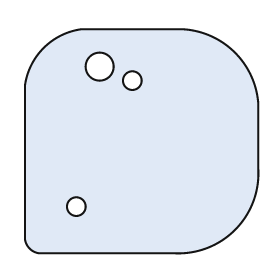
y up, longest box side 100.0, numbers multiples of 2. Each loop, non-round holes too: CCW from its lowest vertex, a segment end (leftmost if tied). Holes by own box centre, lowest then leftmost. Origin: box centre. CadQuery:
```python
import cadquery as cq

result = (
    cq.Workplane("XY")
    .moveTo(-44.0, -48.0)
    .lineTo(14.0, -48.0)
    .threePointArc((40.0, -38.0), (50.0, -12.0))
    .lineTo(50.0, 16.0)
    .threePointArc((40.0, 38.0), (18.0, 48.0))
    .lineTo(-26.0, 48.0)
    .threePointArc((-42.0, 40.0), (-50.0, 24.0))
    .lineTo(-50.0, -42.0)
    .threePointArc((-48.0, -46.0), (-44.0, -48.0))
    .close()
    .moveTo(-28.0, -28.0)
    .circle(4.0)
    .moveTo(-4.0, 26.0)
    .circle(4.0)
    .moveTo(-18.0, 32.0)
    .circle(6.0)
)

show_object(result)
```